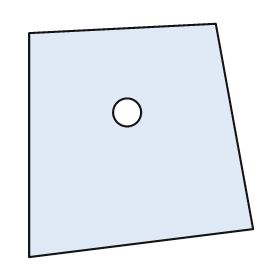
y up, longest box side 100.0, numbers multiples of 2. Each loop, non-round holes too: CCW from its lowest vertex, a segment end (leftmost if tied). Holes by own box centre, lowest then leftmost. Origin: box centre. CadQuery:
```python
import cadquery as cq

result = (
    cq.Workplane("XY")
    .moveTo(-48.0, -50.0)
    .lineTo(48.0, -38.0)
    .lineTo(32.0, 50.0)
    .lineTo(-48.0, 46.0)
    .close()
    .moveTo(-6.0, 12.0)
    .circle(6.0)
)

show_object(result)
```